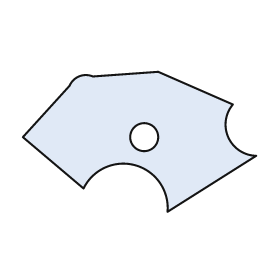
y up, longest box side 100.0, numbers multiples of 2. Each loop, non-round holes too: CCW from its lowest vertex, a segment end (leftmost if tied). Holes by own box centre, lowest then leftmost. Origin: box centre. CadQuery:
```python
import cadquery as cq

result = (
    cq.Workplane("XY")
    .moveTo(12.0, -30.0)
    .lineTo(50.0, -6.0)
    .threePointArc((38.0, 2.0), (40.0, 16.0))
    .lineTo(8.0, 30.0)
    .lineTo(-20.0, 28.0)
    .threePointArc((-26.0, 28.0), (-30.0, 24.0))
    .lineTo(-50.0, 2.0)
    .lineTo(-24.0, -20.0)
    .threePointArc((-2.0, -10.0), (12.0, -30.0))
    .close()
    .moveTo(2.0, 2.0)
    .circle(6.0)
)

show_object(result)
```